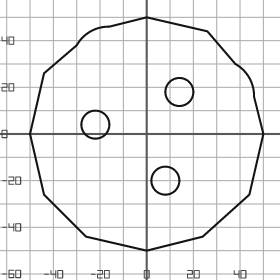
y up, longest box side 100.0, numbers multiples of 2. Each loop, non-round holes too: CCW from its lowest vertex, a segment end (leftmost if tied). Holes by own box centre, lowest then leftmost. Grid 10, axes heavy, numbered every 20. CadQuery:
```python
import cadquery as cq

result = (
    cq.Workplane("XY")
    .moveTo(0.0, -50.0)
    .lineTo(24.0, -44.0)
    .lineTo(44.0, -26.0)
    .lineTo(50.0, 0.0)
    .lineTo(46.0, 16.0)
    .threePointArc((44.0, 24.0), (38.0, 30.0))
    .lineTo(26.0, 44.0)
    .lineTo(0.0, 50.0)
    .lineTo(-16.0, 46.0)
    .threePointArc((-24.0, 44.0), (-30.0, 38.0))
    .lineTo(-44.0, 26.0)
    .lineTo(-50.0, 0.0)
    .lineTo(-44.0, -26.0)
    .lineTo(-26.0, -44.0)
    .close()
    .moveTo(8.0, -20.0)
    .circle(6.0)
    .moveTo(-22.0, 4.0)
    .circle(6.0)
    .moveTo(14.0, 18.0)
    .circle(6.0)
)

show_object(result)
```